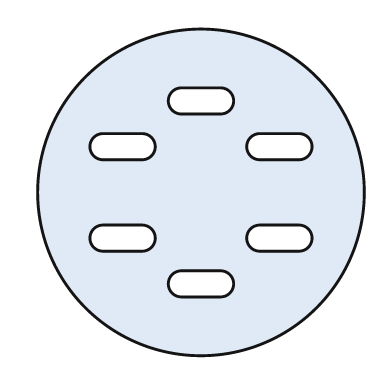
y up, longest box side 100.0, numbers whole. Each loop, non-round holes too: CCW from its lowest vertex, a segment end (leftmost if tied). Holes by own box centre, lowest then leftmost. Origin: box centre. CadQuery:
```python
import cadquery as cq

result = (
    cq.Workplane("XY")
    .moveTo(0.0, 0.0)
    .circle(50.0)
    .moveTo(-6.0, -32.0)
    .lineTo(6.0, -32.0)
    .threePointArc((10.0, -28.0), (6.0, -24.0))
    .lineTo(-6.0, -24.0)
    .threePointArc((-10.0, -28.0), (-6.0, -32.0))
    .close()
    .moveTo(-30.0, -18.0)
    .lineTo(-18.0, -18.0)
    .threePointArc((-14.0, -14.0), (-18.0, -10.0))
    .lineTo(-30.0, -10.0)
    .threePointArc((-34.0, -14.0), (-30.0, -18.0))
    .close()
    .moveTo(18.0, -18.0)
    .lineTo(30.0, -18.0)
    .threePointArc((34.0, -14.0), (30.0, -10.0))
    .lineTo(18.0, -10.0)
    .threePointArc((14.0, -14.0), (18.0, -18.0))
    .close()
    .moveTo(-30.0, 10.0)
    .lineTo(-18.0, 10.0)
    .threePointArc((-14.0, 14.0), (-18.0, 18.0))
    .lineTo(-30.0, 18.0)
    .threePointArc((-34.0, 14.0), (-30.0, 10.0))
    .close()
    .moveTo(18.0, 10.0)
    .lineTo(30.0, 10.0)
    .threePointArc((34.0, 14.0), (30.0, 18.0))
    .lineTo(18.0, 18.0)
    .threePointArc((14.0, 14.0), (18.0, 10.0))
    .close()
    .moveTo(-6.0, 24.0)
    .lineTo(6.0, 24.0)
    .threePointArc((10.0, 28.0), (6.0, 32.0))
    .lineTo(-6.0, 32.0)
    .threePointArc((-10.0, 28.0), (-6.0, 24.0))
    .close()
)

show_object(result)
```